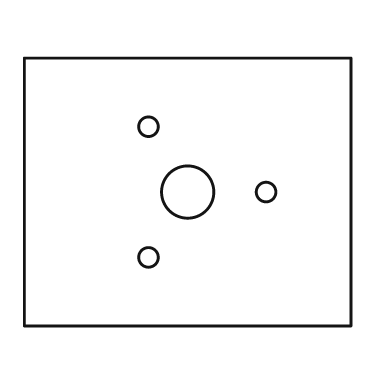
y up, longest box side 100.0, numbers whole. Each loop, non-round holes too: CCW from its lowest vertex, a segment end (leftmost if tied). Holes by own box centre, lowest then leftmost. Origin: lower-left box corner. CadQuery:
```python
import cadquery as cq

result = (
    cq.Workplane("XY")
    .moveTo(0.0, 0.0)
    .lineTo(100.0, 0.0)
    .lineTo(100.0, 82.0)
    .lineTo(0.0, 82.0)
    .close()
    .moveTo(38.0, 21.0)
    .circle(3.0)
    .moveTo(50.0, 41.0)
    .circle(8.0)
    .moveTo(74.0, 41.0)
    .circle(3.0)
    .moveTo(38.0, 61.0)
    .circle(3.0)
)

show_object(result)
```